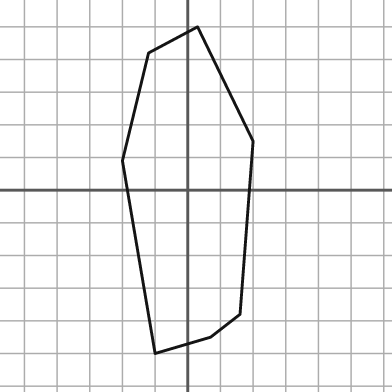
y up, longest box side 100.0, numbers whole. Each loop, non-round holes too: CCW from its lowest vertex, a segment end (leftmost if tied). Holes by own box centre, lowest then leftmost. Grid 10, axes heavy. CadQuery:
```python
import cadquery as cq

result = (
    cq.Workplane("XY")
    .moveTo(-10.0, -50.0)
    .lineTo(7.0, -45.0)
    .lineTo(16.0, -38.0)
    .lineTo(20.0, 15.0)
    .lineTo(3.0, 50.0)
    .lineTo(-12.0, 42.0)
    .lineTo(-20.0, 9.0)
    .close()
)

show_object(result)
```